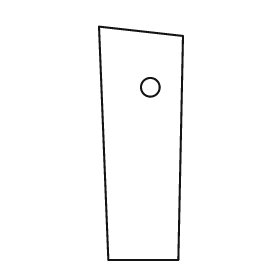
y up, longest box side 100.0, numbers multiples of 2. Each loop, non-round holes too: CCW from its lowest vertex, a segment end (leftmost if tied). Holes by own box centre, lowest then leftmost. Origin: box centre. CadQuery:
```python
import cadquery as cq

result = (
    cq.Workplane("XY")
    .moveTo(-14.0, -50.0)
    .lineTo(16.0, -50.0)
    .lineTo(18.0, 46.0)
    .lineTo(-18.0, 50.0)
    .close()
    .moveTo(4.0, 24.0)
    .circle(4.0)
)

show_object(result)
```